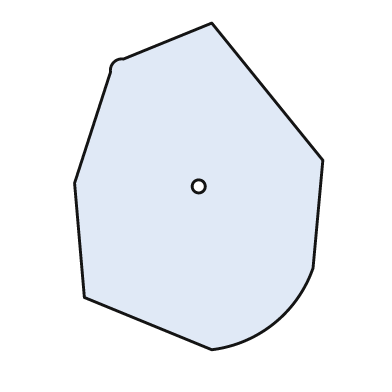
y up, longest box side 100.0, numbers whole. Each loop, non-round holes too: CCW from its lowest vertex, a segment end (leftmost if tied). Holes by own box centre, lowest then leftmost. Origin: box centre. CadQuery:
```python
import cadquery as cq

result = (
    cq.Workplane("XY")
    .moveTo(4.0, -50.0)
    .threePointArc((23.0, -42.0), (35.0, -25.0))
    .lineTo(38.0, 8.0)
    .lineTo(4.0, 50.0)
    .lineTo(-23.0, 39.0)
    .threePointArc((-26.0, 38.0), (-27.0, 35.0))
    .lineTo(-38.0, 1.0)
    .lineTo(-35.0, -34.0)
    .close()
    .moveTo(0.0, 0.0)
    .circle(2.0)
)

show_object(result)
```